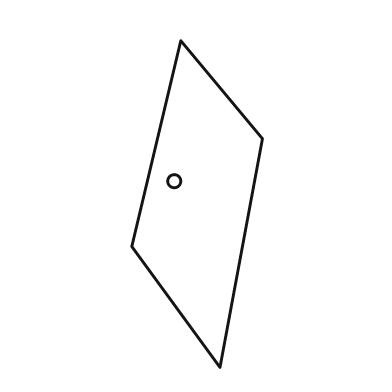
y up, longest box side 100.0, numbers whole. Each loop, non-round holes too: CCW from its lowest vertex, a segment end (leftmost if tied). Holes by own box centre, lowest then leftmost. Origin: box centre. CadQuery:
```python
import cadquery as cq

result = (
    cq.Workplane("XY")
    .moveTo(7.0, -50.0)
    .lineTo(20.0, 20.0)
    .lineTo(-5.0, 50.0)
    .lineTo(-20.0, -13.0)
    .close()
    .moveTo(-7.0, 7.0)
    .circle(2.0)
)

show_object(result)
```